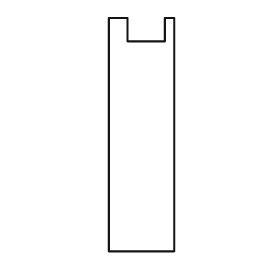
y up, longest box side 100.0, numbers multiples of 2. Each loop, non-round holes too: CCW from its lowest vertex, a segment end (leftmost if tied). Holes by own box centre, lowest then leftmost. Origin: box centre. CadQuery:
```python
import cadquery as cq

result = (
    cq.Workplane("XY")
    .moveTo(-14.0, -50.0)
    .lineTo(14.0, -50.0)
    .lineTo(14.0, 50.0)
    .lineTo(10.0, 50.0)
    .lineTo(10.0, 40.0)
    .lineTo(-6.0, 40.0)
    .lineTo(-6.0, 50.0)
    .lineTo(-14.0, 50.0)
    .close()
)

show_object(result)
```